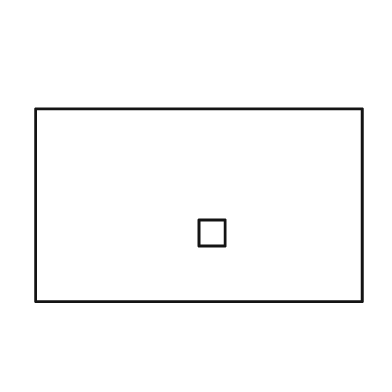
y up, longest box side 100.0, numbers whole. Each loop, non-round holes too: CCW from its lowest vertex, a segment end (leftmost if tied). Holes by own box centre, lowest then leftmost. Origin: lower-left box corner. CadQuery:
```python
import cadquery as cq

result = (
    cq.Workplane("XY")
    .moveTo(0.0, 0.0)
    .lineTo(100.0, 0.0)
    .lineTo(100.0, 59.0)
    .lineTo(0.0, 59.0)
    .close()
    .moveTo(50.0, 17.0)
    .lineTo(58.0, 17.0)
    .lineTo(58.0, 25.0)
    .lineTo(50.0, 25.0)
    .close()
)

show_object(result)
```